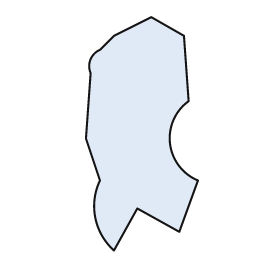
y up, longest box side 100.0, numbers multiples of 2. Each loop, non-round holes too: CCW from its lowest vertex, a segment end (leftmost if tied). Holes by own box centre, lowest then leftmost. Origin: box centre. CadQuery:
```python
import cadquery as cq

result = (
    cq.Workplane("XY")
    .moveTo(-12.0, -50.0)
    .lineTo(-2.0, -32.0)
    .lineTo(16.0, -42.0)
    .lineTo(24.0, -20.0)
    .threePointArc((12.0, -4.0), (20.0, 14.0))
    .lineTo(18.0, 42.0)
    .lineTo(4.0, 50.0)
    .lineTo(-12.0, 42.0)
    .lineTo(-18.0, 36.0)
    .threePointArc((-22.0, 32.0), (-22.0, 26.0))
    .lineTo(-24.0, -2.0)
    .lineTo(-18.0, -20.0)
    .threePointArc((-20.0, -36.0), (-12.0, -50.0))
    .close()
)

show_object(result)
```